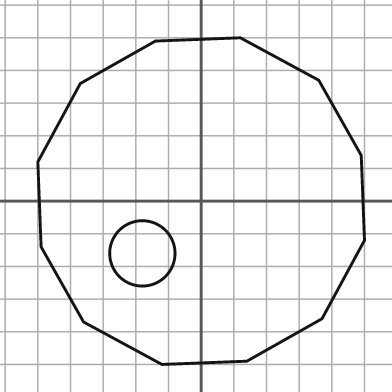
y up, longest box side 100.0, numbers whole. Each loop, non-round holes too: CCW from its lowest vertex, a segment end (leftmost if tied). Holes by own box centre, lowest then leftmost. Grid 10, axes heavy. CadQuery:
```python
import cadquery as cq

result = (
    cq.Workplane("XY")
    .moveTo(-12.0, -50.0)
    .lineTo(14.0, -49.0)
    .lineTo(37.0, -36.0)
    .lineTo(50.0, -12.0)
    .lineTo(49.0, 14.0)
    .lineTo(36.0, 37.0)
    .lineTo(12.0, 50.0)
    .lineTo(-14.0, 49.0)
    .lineTo(-37.0, 36.0)
    .lineTo(-50.0, 12.0)
    .lineTo(-49.0, -14.0)
    .lineTo(-36.0, -37.0)
    .close()
    .moveTo(-18.0, -16.0)
    .circle(10.0)
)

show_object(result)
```